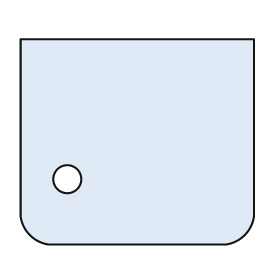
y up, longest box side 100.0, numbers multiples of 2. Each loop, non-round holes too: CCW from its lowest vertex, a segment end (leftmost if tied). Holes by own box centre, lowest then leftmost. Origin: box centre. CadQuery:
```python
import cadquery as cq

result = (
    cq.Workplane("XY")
    .moveTo(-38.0, -44.0)
    .lineTo(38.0, -44.0)
    .threePointArc((46.0, -40.0), (50.0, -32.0))
    .lineTo(50.0, 44.0)
    .lineTo(-50.0, 44.0)
    .lineTo(-50.0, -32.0)
    .threePointArc((-46.0, -40.0), (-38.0, -44.0))
    .close()
    .moveTo(-30.0, -16.0)
    .circle(6.0)
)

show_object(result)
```